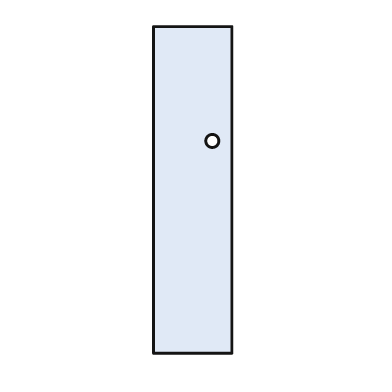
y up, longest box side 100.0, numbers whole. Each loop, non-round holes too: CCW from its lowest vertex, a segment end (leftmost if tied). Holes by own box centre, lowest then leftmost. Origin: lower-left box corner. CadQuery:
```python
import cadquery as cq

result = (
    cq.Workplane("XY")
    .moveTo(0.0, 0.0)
    .lineTo(24.0, 0.0)
    .lineTo(24.0, 100.0)
    .lineTo(0.0, 100.0)
    .close()
    .moveTo(18.0, 65.0)
    .circle(2.0)
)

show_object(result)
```